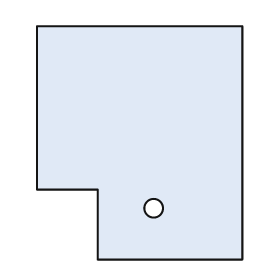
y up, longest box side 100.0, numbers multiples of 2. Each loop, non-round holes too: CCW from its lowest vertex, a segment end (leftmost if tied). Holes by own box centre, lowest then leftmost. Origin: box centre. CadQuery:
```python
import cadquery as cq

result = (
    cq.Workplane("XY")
    .moveTo(-18.0, -50.0)
    .lineTo(44.0, -50.0)
    .lineTo(44.0, 50.0)
    .lineTo(-44.0, 50.0)
    .lineTo(-44.0, -20.0)
    .lineTo(-18.0, -20.0)
    .close()
    .moveTo(6.0, -28.0)
    .circle(4.0)
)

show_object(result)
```